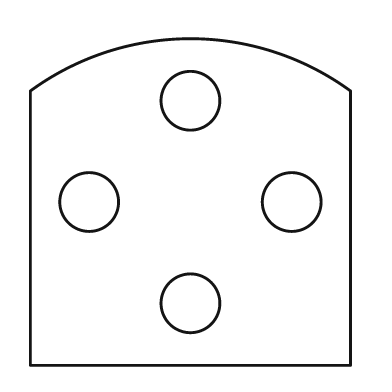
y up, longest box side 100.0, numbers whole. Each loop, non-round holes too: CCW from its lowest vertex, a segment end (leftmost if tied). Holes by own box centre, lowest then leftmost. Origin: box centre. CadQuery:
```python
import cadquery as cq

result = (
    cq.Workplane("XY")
    .moveTo(-49.0, -50.0)
    .lineTo(49.0, -50.0)
    .lineTo(49.0, 34.0)
    .threePointArc((0.0, 50.0), (-49.0, 34.0))
    .close()
    .moveTo(0.0, -31.0)
    .circle(9.0)
    .moveTo(-31.0, 0.0)
    .circle(9.0)
    .moveTo(31.0, 0.0)
    .circle(9.0)
    .moveTo(0.0, 31.0)
    .circle(9.0)
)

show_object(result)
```